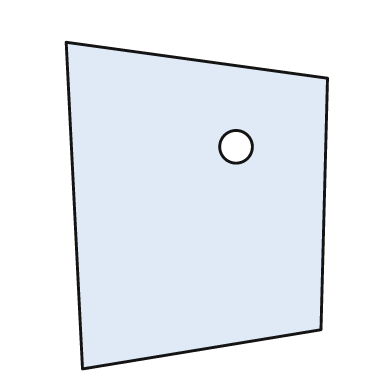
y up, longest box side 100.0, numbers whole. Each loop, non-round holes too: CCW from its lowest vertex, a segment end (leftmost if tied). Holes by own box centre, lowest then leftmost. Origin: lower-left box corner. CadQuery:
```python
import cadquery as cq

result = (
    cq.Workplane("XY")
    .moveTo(5.0, 0.0)
    .lineTo(78.0, 12.0)
    .lineTo(80.0, 89.0)
    .lineTo(0.0, 100.0)
    .close()
    .moveTo(52.0, 68.0)
    .circle(5.0)
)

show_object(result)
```